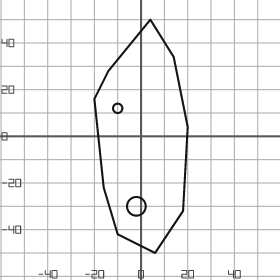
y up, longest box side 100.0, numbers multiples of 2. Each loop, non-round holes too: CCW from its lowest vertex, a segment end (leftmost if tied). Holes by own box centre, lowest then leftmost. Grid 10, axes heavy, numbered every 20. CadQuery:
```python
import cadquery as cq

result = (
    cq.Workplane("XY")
    .moveTo(6.0, -50.0)
    .lineTo(18.0, -32.0)
    .lineTo(20.0, 4.0)
    .lineTo(14.0, 34.0)
    .lineTo(4.0, 50.0)
    .lineTo(-14.0, 28.0)
    .lineTo(-20.0, 16.0)
    .lineTo(-16.0, -22.0)
    .lineTo(-10.0, -42.0)
    .close()
    .moveTo(-2.0, -30.0)
    .circle(4.0)
    .moveTo(-10.0, 12.0)
    .circle(2.0)
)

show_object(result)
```